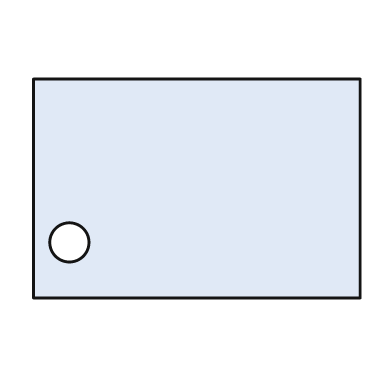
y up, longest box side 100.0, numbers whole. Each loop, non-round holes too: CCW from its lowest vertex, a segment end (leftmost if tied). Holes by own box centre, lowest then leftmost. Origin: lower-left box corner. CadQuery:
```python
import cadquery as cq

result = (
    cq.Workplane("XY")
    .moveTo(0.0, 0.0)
    .lineTo(100.0, 0.0)
    .lineTo(100.0, 67.0)
    .lineTo(0.0, 67.0)
    .close()
    .moveTo(11.0, 17.0)
    .circle(6.0)
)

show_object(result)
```